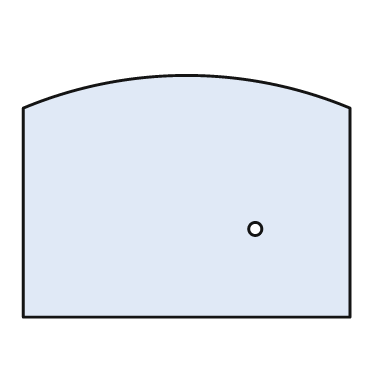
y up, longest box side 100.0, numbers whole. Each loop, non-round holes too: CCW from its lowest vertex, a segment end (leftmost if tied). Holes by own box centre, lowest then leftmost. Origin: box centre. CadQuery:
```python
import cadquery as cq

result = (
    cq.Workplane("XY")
    .moveTo(-50.0, -37.0)
    .lineTo(50.0, -37.0)
    .lineTo(50.0, 27.0)
    .threePointArc((0.0, 37.0), (-50.0, 27.0))
    .close()
    .moveTo(21.0, -10.0)
    .circle(2.0)
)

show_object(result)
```